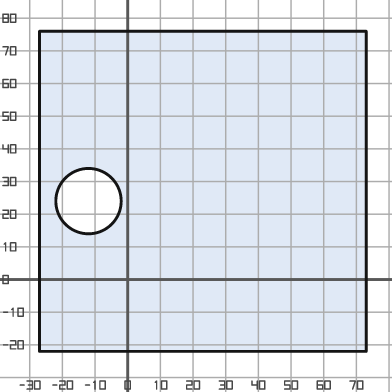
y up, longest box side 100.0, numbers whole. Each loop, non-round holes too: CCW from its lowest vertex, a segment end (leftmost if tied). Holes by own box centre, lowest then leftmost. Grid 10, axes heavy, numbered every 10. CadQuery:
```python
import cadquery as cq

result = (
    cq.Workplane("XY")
    .moveTo(-27.0, -22.0)
    .lineTo(73.0, -22.0)
    .lineTo(73.0, 76.0)
    .lineTo(-27.0, 76.0)
    .close()
    .moveTo(-12.0, 24.0)
    .circle(10.0)
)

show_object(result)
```